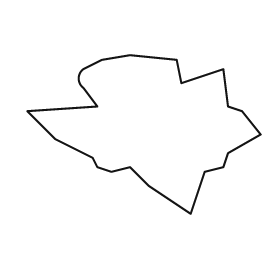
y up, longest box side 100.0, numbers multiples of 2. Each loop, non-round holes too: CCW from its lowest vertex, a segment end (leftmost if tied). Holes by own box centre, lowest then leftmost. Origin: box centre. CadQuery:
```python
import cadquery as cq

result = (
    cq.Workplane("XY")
    .moveTo(20.0, -34.0)
    .lineTo(26.0, -16.0)
    .lineTo(34.0, -14.0)
    .lineTo(36.0, -8.0)
    .lineTo(50.0, 0.0)
    .lineTo(42.0, 10.0)
    .lineTo(36.0, 12.0)
    .lineTo(34.0, 28.0)
    .lineTo(16.0, 22.0)
    .lineTo(14.0, 32.0)
    .lineTo(-6.0, 34.0)
    .lineTo(-18.0, 32.0)
    .lineTo(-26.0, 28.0)
    .threePointArc((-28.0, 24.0), (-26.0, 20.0))
    .lineTo(-20.0, 12.0)
    .lineTo(-50.0, 10.0)
    .lineTo(-38.0, -2.0)
    .lineTo(-22.0, -10.0)
    .lineTo(-20.0, -14.0)
    .lineTo(-14.0, -16.0)
    .lineTo(-6.0, -14.0)
    .lineTo(2.0, -22.0)
    .close()
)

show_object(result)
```